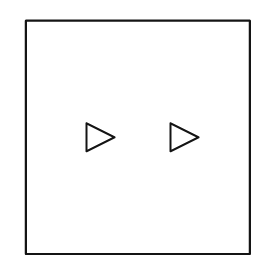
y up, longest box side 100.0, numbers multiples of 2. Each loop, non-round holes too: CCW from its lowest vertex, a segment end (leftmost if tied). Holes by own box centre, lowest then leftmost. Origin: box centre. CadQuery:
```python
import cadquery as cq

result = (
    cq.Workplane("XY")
    .moveTo(-48.0, -50.0)
    .lineTo(48.0, -50.0)
    .lineTo(48.0, 50.0)
    .lineTo(-48.0, 50.0)
    .close()
    .moveTo(-22.0, -6.0)
    .lineTo(-10.0, 0.0)
    .lineTo(-22.0, 6.0)
    .close()
    .moveTo(14.0, -6.0)
    .lineTo(26.0, 0.0)
    .lineTo(14.0, 6.0)
    .close()
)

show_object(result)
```